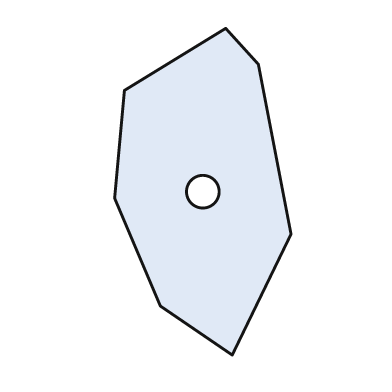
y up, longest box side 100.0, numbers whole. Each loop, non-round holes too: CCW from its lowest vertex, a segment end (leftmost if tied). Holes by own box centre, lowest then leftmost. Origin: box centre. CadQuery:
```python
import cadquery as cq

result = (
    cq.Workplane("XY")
    .moveTo(9.0, -50.0)
    .lineTo(27.0, -13.0)
    .lineTo(17.0, 39.0)
    .lineTo(7.0, 50.0)
    .lineTo(-24.0, 31.0)
    .lineTo(-27.0, -2.0)
    .lineTo(-13.0, -35.0)
    .close()
    .moveTo(0.0, 0.0)
    .circle(5.0)
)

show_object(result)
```